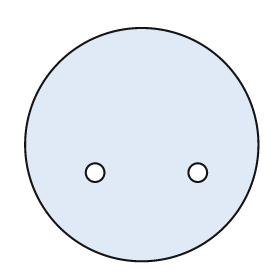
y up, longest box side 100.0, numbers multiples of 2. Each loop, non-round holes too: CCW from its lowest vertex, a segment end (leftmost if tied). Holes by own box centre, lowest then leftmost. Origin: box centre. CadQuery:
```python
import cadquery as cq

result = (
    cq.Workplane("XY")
    .moveTo(0.0, 0.0)
    .circle(50.0)
    .moveTo(-20.0, -12.0)
    .circle(4.0)
    .moveTo(24.0, -12.0)
    .circle(4.0)
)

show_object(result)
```